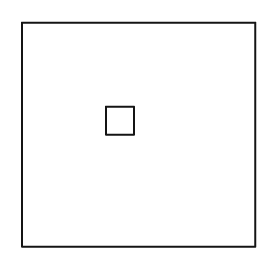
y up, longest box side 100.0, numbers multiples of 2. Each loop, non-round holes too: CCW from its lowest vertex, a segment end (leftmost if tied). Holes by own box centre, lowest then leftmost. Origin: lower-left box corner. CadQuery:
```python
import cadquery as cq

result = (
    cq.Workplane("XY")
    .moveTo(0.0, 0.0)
    .lineTo(100.0, 0.0)
    .lineTo(100.0, 96.0)
    .lineTo(0.0, 96.0)
    .close()
    .moveTo(36.0, 48.0)
    .lineTo(48.0, 48.0)
    .lineTo(48.0, 60.0)
    .lineTo(36.0, 60.0)
    .close()
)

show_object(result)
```